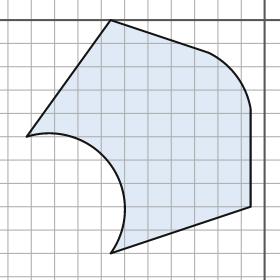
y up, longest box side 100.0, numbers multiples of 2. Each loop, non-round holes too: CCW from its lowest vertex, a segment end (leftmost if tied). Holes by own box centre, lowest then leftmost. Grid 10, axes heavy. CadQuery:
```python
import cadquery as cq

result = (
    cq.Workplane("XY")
    .moveTo(-66.0, -100.0)
    .lineTo(-6.0, -80.0)
    .lineTo(-6.0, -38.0)
    .threePointArc((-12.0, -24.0), (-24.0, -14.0))
    .lineTo(-66.0, 0.0)
    .lineTo(-102.0, -50.0)
    .threePointArc((-66.0, -62.0), (-66.0, -100.0))
    .close()
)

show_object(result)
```